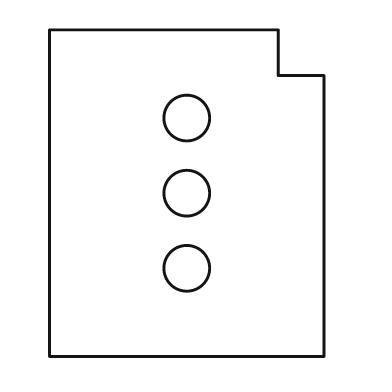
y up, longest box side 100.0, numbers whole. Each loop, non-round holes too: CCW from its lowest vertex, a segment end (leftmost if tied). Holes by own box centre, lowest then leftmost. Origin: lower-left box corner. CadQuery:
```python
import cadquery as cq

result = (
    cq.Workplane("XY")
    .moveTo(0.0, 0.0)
    .lineTo(84.0, 0.0)
    .lineTo(84.0, 86.0)
    .lineTo(70.0, 86.0)
    .lineTo(70.0, 100.0)
    .lineTo(0.0, 100.0)
    .close()
    .moveTo(42.0, 27.0)
    .circle(7.0)
    .moveTo(42.0, 50.0)
    .circle(7.0)
    .moveTo(42.0, 73.0)
    .circle(7.0)
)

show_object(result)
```